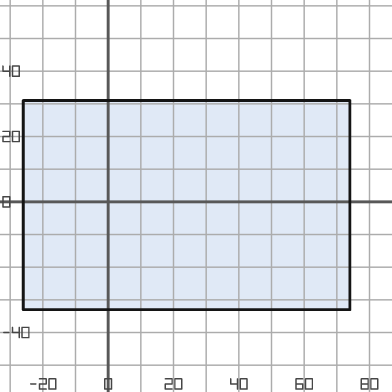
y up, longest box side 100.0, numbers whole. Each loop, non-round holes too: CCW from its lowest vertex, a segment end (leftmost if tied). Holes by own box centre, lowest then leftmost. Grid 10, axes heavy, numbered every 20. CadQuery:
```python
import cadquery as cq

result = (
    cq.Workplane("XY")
    .moveTo(-26.0, -33.0)
    .lineTo(74.0, -33.0)
    .lineTo(74.0, 31.0)
    .lineTo(-26.0, 31.0)
    .close()
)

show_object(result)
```